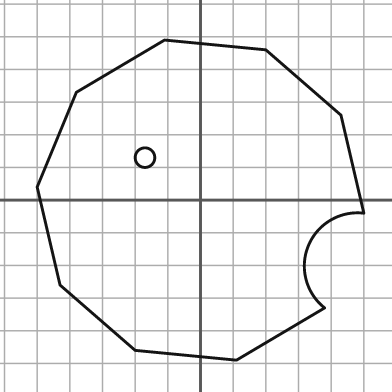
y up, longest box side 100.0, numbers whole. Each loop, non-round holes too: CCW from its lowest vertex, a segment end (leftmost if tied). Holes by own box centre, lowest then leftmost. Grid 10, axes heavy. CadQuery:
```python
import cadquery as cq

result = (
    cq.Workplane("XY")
    .moveTo(11.0, -49.0)
    .lineTo(38.0, -33.0)
    .threePointArc((33.0, -14.0), (50.0, -4.0))
    .lineTo(43.0, 26.0)
    .lineTo(20.0, 46.0)
    .lineTo(-11.0, 49.0)
    .lineTo(-38.0, 33.0)
    .lineTo(-50.0, 4.0)
    .lineTo(-43.0, -26.0)
    .lineTo(-20.0, -46.0)
    .close()
    .moveTo(-17.0, 13.0)
    .circle(3.0)
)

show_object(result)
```